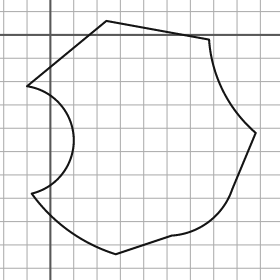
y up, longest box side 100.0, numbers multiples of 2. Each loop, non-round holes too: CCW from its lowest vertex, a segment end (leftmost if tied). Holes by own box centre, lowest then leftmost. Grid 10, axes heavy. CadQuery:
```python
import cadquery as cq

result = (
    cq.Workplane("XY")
    .moveTo(28.0, -94.0)
    .lineTo(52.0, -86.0)
    .threePointArc((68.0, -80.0), (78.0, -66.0))
    .lineTo(88.0, -42.0)
    .threePointArc((74.0, -24.0), (68.0, -2.0))
    .lineTo(24.0, 6.0)
    .lineTo(-10.0, -22.0)
    .threePointArc((10.0, -44.0), (-8.0, -68.0))
    .threePointArc((8.0, -84.0), (28.0, -94.0))
    .close()
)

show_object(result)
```